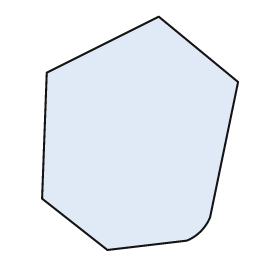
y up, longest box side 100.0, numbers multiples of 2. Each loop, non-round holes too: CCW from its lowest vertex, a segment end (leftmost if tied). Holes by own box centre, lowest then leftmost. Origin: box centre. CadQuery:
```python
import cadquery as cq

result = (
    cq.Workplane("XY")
    .moveTo(-14.0, -50.0)
    .lineTo(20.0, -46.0)
    .threePointArc((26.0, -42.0), (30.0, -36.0))
    .lineTo(42.0, 22.0)
    .lineTo(8.0, 50.0)
    .lineTo(-40.0, 26.0)
    .lineTo(-42.0, -28.0)
    .close()
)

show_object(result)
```